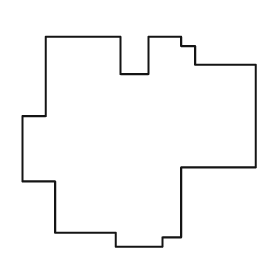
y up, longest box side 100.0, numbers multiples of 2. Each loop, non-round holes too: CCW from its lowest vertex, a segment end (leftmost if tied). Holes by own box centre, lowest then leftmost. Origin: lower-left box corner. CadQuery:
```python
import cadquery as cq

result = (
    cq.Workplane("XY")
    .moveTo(40.0, 0.0)
    .lineTo(60.0, 0.0)
    .lineTo(60.0, 4.0)
    .lineTo(68.0, 4.0)
    .lineTo(68.0, 34.0)
    .lineTo(100.0, 34.0)
    .lineTo(100.0, 78.0)
    .lineTo(74.0, 78.0)
    .lineTo(74.0, 86.0)
    .lineTo(68.0, 86.0)
    .lineTo(68.0, 90.0)
    .lineTo(54.0, 90.0)
    .lineTo(54.0, 74.0)
    .lineTo(42.0, 74.0)
    .lineTo(42.0, 90.0)
    .lineTo(10.0, 90.0)
    .lineTo(10.0, 56.0)
    .lineTo(0.0, 56.0)
    .lineTo(0.0, 28.0)
    .lineTo(14.0, 28.0)
    .lineTo(14.0, 6.0)
    .lineTo(40.0, 6.0)
    .close()
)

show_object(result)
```